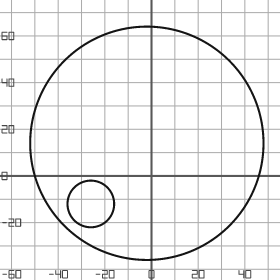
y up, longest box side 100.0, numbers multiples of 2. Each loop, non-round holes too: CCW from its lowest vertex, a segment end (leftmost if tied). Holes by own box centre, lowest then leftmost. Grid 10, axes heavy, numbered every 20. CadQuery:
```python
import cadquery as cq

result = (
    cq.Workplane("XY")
    .moveTo(-2.0, 14.0)
    .circle(50.0)
    .moveTo(-26.0, -12.0)
    .circle(10.0)
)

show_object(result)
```